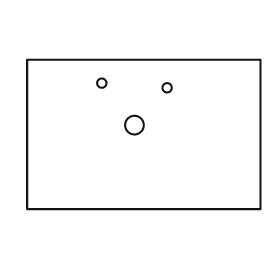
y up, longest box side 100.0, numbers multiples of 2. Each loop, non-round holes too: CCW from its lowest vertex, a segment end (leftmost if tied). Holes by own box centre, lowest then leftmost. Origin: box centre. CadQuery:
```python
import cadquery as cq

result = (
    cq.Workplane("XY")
    .moveTo(-50.0, -32.0)
    .lineTo(50.0, -32.0)
    .lineTo(50.0, 32.0)
    .lineTo(-50.0, 32.0)
    .close()
    .moveTo(-4.0, 4.0)
    .circle(4.0)
    .moveTo(10.0, 20.0)
    .circle(2.0)
    .moveTo(-18.0, 22.0)
    .circle(2.0)
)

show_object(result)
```